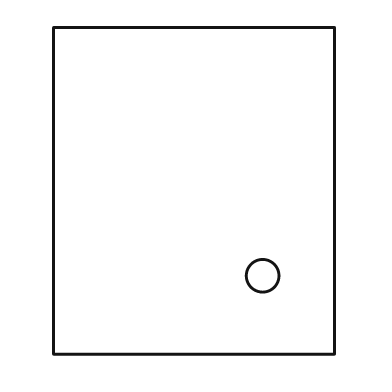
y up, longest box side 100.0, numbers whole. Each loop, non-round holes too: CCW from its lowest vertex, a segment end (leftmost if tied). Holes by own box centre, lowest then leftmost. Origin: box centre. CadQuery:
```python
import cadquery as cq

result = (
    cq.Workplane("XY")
    .moveTo(-43.0, -50.0)
    .lineTo(43.0, -50.0)
    .lineTo(43.0, 50.0)
    .lineTo(-43.0, 50.0)
    .close()
    .moveTo(21.0, -26.0)
    .circle(5.0)
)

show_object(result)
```